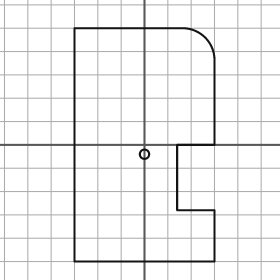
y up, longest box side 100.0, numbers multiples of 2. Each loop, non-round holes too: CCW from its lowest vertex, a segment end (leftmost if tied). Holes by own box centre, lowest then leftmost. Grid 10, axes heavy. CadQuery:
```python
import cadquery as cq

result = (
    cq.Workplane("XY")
    .moveTo(-30.0, -50.0)
    .lineTo(30.0, -50.0)
    .lineTo(30.0, -28.0)
    .lineTo(14.0, -28.0)
    .lineTo(14.0, 0.0)
    .lineTo(30.0, 0.0)
    .lineTo(30.0, 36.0)
    .threePointArc((26.0, 46.0), (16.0, 50.0))
    .lineTo(-30.0, 50.0)
    .close()
    .moveTo(0.0, -4.0)
    .circle(2.0)
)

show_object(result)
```